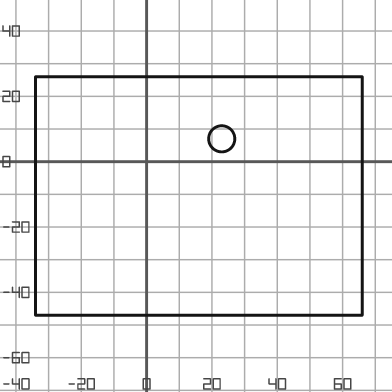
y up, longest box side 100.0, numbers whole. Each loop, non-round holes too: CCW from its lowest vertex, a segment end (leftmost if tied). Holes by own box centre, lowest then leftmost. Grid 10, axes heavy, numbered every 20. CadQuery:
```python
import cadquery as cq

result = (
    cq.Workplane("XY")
    .moveTo(-34.0, -47.0)
    .lineTo(66.0, -47.0)
    .lineTo(66.0, 26.0)
    .lineTo(-34.0, 26.0)
    .close()
    .moveTo(23.0, 7.0)
    .circle(4.0)
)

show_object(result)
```